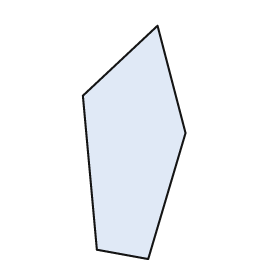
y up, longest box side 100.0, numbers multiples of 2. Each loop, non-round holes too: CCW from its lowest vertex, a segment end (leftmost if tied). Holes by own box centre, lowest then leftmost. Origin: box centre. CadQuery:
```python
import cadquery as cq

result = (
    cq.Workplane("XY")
    .moveTo(6.0, -50.0)
    .lineTo(22.0, 4.0)
    .lineTo(10.0, 50.0)
    .lineTo(-22.0, 20.0)
    .lineTo(-16.0, -46.0)
    .close()
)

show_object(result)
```